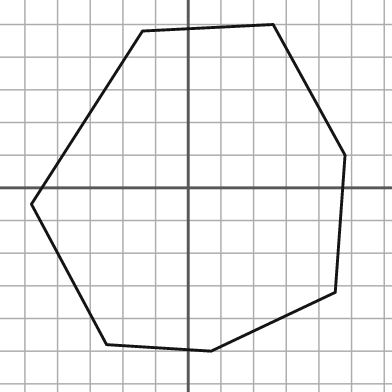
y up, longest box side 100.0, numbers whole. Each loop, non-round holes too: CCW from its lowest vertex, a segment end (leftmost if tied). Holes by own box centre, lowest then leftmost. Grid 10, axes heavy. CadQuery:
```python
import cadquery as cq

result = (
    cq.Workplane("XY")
    .moveTo(7.0, -50.0)
    .lineTo(45.0, -32.0)
    .lineTo(48.0, 10.0)
    .lineTo(26.0, 50.0)
    .lineTo(-14.0, 48.0)
    .lineTo(-48.0, -5.0)
    .lineTo(-25.0, -48.0)
    .close()
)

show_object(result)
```